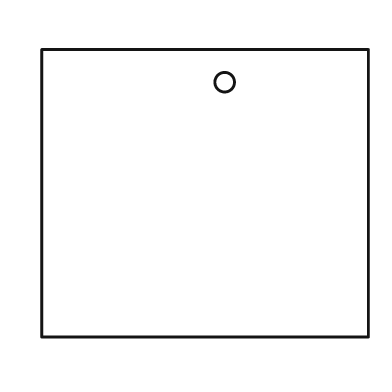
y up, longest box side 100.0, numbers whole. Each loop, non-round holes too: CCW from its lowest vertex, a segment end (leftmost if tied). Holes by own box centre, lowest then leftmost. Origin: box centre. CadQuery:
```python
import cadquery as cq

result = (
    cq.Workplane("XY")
    .moveTo(-50.0, -44.0)
    .lineTo(50.0, -44.0)
    .lineTo(50.0, 44.0)
    .lineTo(-50.0, 44.0)
    .close()
    .moveTo(6.0, 34.0)
    .circle(3.0)
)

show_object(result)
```